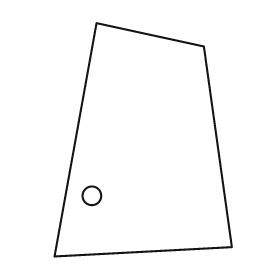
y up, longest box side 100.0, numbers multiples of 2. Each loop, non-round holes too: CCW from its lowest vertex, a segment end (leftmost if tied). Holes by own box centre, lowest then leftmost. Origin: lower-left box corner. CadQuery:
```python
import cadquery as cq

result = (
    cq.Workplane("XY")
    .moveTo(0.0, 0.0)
    .lineTo(76.0, 4.0)
    .lineTo(64.0, 90.0)
    .lineTo(18.0, 100.0)
    .close()
    .moveTo(16.0, 26.0)
    .circle(4.0)
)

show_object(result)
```